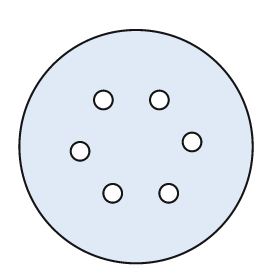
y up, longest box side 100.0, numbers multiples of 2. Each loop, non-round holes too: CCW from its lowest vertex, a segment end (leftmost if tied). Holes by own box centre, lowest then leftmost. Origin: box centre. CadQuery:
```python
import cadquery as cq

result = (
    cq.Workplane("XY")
    .moveTo(0.0, 0.0)
    .circle(50.0)
    .moveTo(-10.0, -20.0)
    .circle(4.0)
    .moveTo(14.0, -20.0)
    .circle(4.0)
    .moveTo(-24.0, -2.0)
    .circle(4.0)
    .moveTo(24.0, 2.0)
    .circle(4.0)
    .moveTo(-14.0, 20.0)
    .circle(4.0)
    .moveTo(10.0, 20.0)
    .circle(4.0)
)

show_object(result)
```